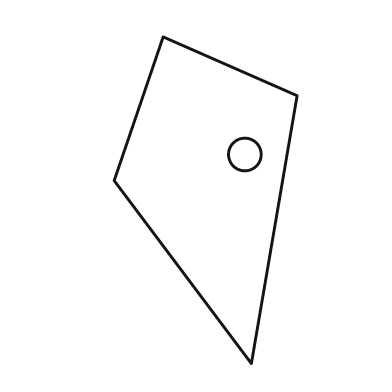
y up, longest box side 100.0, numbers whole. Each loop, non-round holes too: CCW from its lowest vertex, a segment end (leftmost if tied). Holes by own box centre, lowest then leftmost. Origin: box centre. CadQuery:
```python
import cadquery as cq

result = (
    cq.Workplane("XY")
    .moveTo(14.0, -50.0)
    .lineTo(28.0, 32.0)
    .lineTo(-13.0, 50.0)
    .lineTo(-28.0, 6.0)
    .close()
    .moveTo(12.0, 14.0)
    .circle(5.0)
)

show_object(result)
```